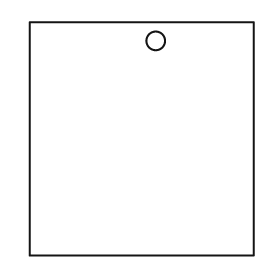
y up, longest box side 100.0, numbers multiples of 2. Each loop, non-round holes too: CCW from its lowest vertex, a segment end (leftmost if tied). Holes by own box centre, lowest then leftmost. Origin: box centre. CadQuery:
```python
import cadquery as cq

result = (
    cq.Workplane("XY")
    .moveTo(-48.0, -50.0)
    .lineTo(48.0, -50.0)
    .lineTo(48.0, 50.0)
    .lineTo(-48.0, 50.0)
    .close()
    .moveTo(6.0, 42.0)
    .circle(4.0)
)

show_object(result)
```